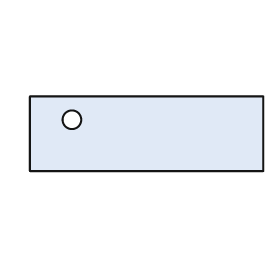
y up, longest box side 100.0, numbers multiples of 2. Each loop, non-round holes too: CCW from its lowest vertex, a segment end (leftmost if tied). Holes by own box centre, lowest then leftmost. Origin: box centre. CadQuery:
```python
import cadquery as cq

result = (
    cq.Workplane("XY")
    .moveTo(-50.0, -16.0)
    .lineTo(50.0, -16.0)
    .lineTo(50.0, 16.0)
    .lineTo(-50.0, 16.0)
    .close()
    .moveTo(-32.0, 6.0)
    .circle(4.0)
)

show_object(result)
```